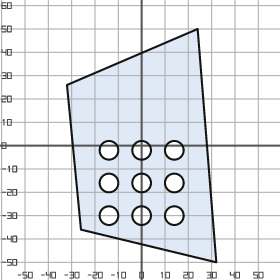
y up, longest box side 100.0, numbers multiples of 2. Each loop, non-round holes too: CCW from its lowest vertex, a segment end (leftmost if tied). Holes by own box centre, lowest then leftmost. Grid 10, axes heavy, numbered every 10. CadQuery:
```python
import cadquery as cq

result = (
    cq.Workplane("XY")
    .moveTo(32.0, -50.0)
    .lineTo(24.0, 50.0)
    .lineTo(-32.0, 26.0)
    .lineTo(-26.0, -36.0)
    .close()
    .moveTo(-14.0, -30.0)
    .circle(4.0)
    .moveTo(0.0, -30.0)
    .circle(4.0)
    .moveTo(14.0, -30.0)
    .circle(4.0)
    .moveTo(-14.0, -16.0)
    .circle(4.0)
    .moveTo(0.0, -16.0)
    .circle(4.0)
    .moveTo(14.0, -16.0)
    .circle(4.0)
    .moveTo(-14.0, -2.0)
    .circle(4.0)
    .moveTo(0.0, -2.0)
    .circle(4.0)
    .moveTo(14.0, -2.0)
    .circle(4.0)
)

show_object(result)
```